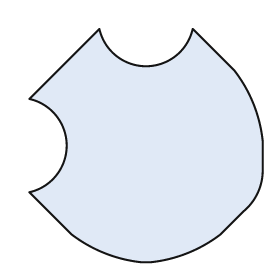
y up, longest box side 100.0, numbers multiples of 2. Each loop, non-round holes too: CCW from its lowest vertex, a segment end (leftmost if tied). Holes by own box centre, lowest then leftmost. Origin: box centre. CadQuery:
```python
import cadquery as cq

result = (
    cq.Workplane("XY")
    .moveTo(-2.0, -50.0)
    .lineTo(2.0, -50.0)
    .threePointArc((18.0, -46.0), (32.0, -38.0))
    .lineTo(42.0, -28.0)
    .threePointArc((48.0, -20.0), (50.0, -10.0))
    .lineTo(50.0, 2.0)
    .threePointArc((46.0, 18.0), (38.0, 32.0))
    .lineTo(20.0, 50.0)
    .threePointArc((0.0, 34.0), (-20.0, 50.0))
    .lineTo(-50.0, 20.0)
    .threePointArc((-34.0, 0.0), (-50.0, -20.0))
    .lineTo(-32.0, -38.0)
    .threePointArc((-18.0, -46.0), (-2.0, -50.0))
    .close()
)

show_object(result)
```